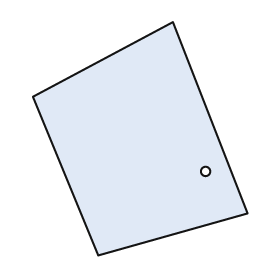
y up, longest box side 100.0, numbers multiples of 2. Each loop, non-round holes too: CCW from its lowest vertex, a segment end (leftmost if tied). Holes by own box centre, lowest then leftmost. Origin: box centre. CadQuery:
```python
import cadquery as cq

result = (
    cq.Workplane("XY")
    .moveTo(-18.0, -50.0)
    .lineTo(46.0, -32.0)
    .lineTo(14.0, 50.0)
    .lineTo(-46.0, 18.0)
    .close()
    .moveTo(28.0, -14.0)
    .circle(2.0)
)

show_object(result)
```